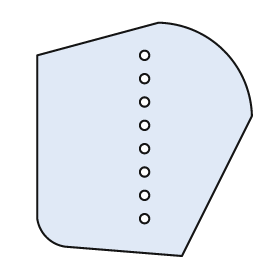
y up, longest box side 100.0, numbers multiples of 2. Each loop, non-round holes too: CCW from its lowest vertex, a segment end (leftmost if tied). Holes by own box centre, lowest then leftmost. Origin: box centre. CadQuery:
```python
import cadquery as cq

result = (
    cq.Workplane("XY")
    .moveTo(16.0, -50.0)
    .lineTo(46.0, 10.0)
    .threePointArc((34.0, 38.0), (6.0, 50.0))
    .lineTo(-46.0, 36.0)
    .lineTo(-46.0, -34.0)
    .threePointArc((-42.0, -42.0), (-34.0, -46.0))
    .close()
    .moveTo(0.0, -34.0)
    .circle(2.0)
    .moveTo(0.0, -24.0)
    .circle(2.0)
    .moveTo(0.0, -14.0)
    .circle(2.0)
    .moveTo(0.0, -4.0)
    .circle(2.0)
    .moveTo(0.0, 6.0)
    .circle(2.0)
    .moveTo(0.0, 16.0)
    .circle(2.0)
    .moveTo(0.0, 26.0)
    .circle(2.0)
    .moveTo(0.0, 36.0)
    .circle(2.0)
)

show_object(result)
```